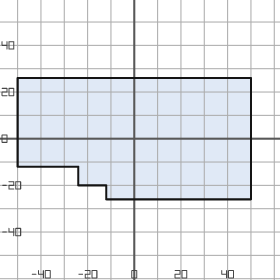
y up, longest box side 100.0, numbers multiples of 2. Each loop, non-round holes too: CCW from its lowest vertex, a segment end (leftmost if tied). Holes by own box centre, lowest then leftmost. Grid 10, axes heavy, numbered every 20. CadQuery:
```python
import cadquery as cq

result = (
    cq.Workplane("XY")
    .moveTo(-12.0, -26.0)
    .lineTo(50.0, -26.0)
    .lineTo(50.0, 26.0)
    .lineTo(-50.0, 26.0)
    .lineTo(-50.0, -12.0)
    .lineTo(-24.0, -12.0)
    .lineTo(-24.0, -20.0)
    .lineTo(-12.0, -20.0)
    .close()
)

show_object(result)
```